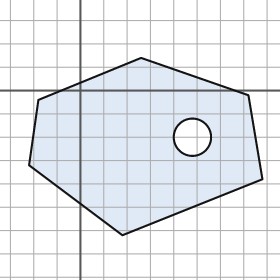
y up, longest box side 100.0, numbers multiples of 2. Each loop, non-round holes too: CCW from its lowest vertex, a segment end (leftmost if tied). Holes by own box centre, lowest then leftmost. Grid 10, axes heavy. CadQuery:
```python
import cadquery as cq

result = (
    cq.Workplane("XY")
    .moveTo(18.0, -62.0)
    .lineTo(78.0, -38.0)
    .lineTo(72.0, -2.0)
    .lineTo(26.0, 14.0)
    .lineTo(-18.0, -4.0)
    .lineTo(-22.0, -32.0)
    .close()
    .moveTo(48.0, -20.0)
    .circle(8.0)
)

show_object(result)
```